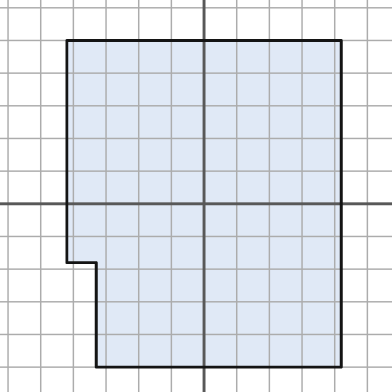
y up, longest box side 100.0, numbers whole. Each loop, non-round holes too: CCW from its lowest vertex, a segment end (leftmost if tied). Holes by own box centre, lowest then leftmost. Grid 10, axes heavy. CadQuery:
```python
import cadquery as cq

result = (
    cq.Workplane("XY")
    .moveTo(-33.0, -50.0)
    .lineTo(42.0, -50.0)
    .lineTo(42.0, 50.0)
    .lineTo(-42.0, 50.0)
    .lineTo(-42.0, -18.0)
    .lineTo(-33.0, -18.0)
    .close()
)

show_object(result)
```